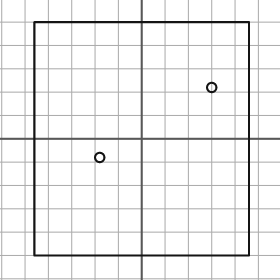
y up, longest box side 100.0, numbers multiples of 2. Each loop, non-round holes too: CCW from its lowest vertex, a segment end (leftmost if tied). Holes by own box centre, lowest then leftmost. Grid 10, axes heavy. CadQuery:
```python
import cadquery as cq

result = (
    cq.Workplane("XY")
    .moveTo(-46.0, -50.0)
    .lineTo(46.0, -50.0)
    .lineTo(46.0, 50.0)
    .lineTo(-46.0, 50.0)
    .close()
    .moveTo(-18.0, -8.0)
    .circle(2.0)
    .moveTo(30.0, 22.0)
    .circle(2.0)
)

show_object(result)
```